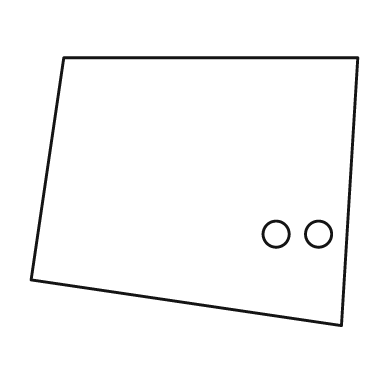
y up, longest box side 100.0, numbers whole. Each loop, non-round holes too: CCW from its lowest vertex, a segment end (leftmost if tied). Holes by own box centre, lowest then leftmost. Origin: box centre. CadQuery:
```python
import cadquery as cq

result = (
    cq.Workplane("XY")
    .moveTo(45.0, -41.0)
    .lineTo(50.0, 41.0)
    .lineTo(-40.0, 41.0)
    .lineTo(-50.0, -27.0)
    .close()
    .moveTo(25.0, -13.0)
    .circle(4.0)
    .moveTo(38.0, -13.0)
    .circle(4.0)
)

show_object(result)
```